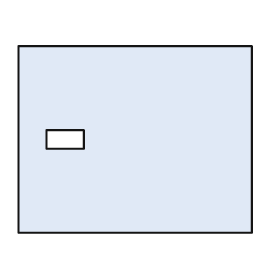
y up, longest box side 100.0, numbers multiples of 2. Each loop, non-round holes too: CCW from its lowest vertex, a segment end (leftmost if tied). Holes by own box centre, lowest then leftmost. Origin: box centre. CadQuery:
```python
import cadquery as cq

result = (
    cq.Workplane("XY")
    .moveTo(-50.0, -40.0)
    .lineTo(50.0, -40.0)
    .lineTo(50.0, 40.0)
    .lineTo(-50.0, 40.0)
    .close()
    .moveTo(-38.0, -4.0)
    .lineTo(-22.0, -4.0)
    .lineTo(-22.0, 4.0)
    .lineTo(-38.0, 4.0)
    .close()
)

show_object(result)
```